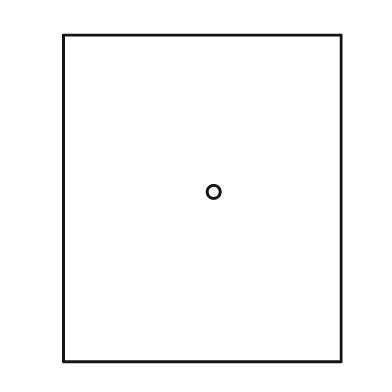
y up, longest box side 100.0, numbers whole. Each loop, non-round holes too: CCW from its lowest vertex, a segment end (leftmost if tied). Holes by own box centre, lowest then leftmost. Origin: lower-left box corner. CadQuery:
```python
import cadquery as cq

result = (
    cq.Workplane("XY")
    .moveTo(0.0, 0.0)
    .lineTo(85.0, 0.0)
    .lineTo(85.0, 100.0)
    .lineTo(0.0, 100.0)
    .close()
    .moveTo(46.0, 52.0)
    .circle(2.0)
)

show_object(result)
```